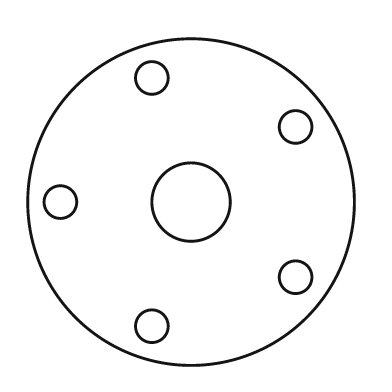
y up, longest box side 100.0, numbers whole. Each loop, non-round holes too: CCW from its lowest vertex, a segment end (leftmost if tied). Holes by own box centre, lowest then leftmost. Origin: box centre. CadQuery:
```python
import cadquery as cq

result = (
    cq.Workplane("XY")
    .moveTo(0.0, 0.0)
    .circle(50.0)
    .moveTo(-12.0, -38.0)
    .circle(5.0)
    .moveTo(32.0, -23.0)
    .circle(5.0)
    .moveTo(-40.0, 0.0)
    .circle(5.0)
    .moveTo(0.0, 0.0)
    .circle(12.0)
    .moveTo(32.0, 23.0)
    .circle(5.0)
    .moveTo(-12.0, 38.0)
    .circle(5.0)
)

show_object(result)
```